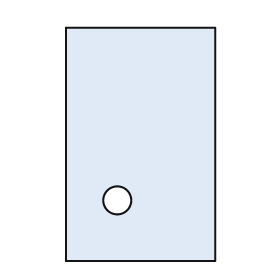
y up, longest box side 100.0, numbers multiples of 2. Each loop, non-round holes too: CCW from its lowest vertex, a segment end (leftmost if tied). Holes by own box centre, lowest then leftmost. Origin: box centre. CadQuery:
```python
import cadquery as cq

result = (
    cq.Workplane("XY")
    .moveTo(-32.0, -50.0)
    .lineTo(32.0, -50.0)
    .lineTo(32.0, 50.0)
    .lineTo(-32.0, 50.0)
    .close()
    .moveTo(-10.0, -24.0)
    .circle(6.0)
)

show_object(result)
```